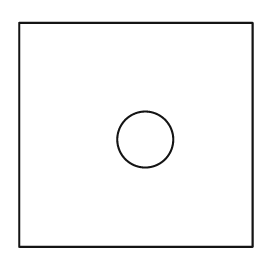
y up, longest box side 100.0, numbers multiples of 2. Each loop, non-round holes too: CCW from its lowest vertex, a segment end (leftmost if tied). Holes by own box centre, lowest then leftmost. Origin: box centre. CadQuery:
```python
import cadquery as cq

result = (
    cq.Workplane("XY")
    .moveTo(-50.0, -48.0)
    .lineTo(50.0, -48.0)
    .lineTo(50.0, 48.0)
    .lineTo(-50.0, 48.0)
    .close()
    .moveTo(4.0, -2.0)
    .circle(12.0)
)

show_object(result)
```